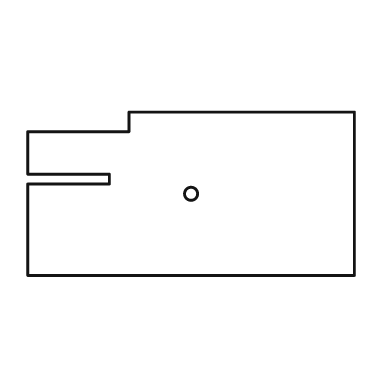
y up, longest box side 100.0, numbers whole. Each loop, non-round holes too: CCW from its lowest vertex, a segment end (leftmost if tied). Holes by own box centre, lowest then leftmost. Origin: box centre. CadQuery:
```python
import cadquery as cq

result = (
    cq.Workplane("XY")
    .moveTo(-50.0, -25.0)
    .lineTo(50.0, -25.0)
    .lineTo(50.0, 25.0)
    .lineTo(-19.0, 25.0)
    .lineTo(-19.0, 19.0)
    .lineTo(-50.0, 19.0)
    .lineTo(-50.0, 6.0)
    .lineTo(-25.0, 6.0)
    .lineTo(-25.0, 3.0)
    .lineTo(-50.0, 3.0)
    .close()
    .moveTo(0.0, 0.0)
    .circle(2.0)
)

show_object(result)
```